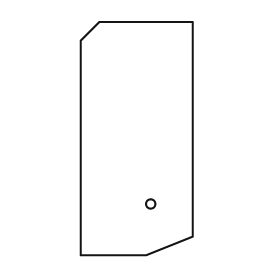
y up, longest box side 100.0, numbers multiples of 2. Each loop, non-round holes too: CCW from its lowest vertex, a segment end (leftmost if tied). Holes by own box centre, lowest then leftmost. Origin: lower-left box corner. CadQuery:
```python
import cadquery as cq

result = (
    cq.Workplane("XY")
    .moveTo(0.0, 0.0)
    .lineTo(28.0, 0.0)
    .lineTo(48.0, 8.0)
    .lineTo(48.0, 100.0)
    .lineTo(8.0, 100.0)
    .lineTo(0.0, 92.0)
    .close()
    .moveTo(30.0, 22.0)
    .circle(2.0)
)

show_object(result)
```